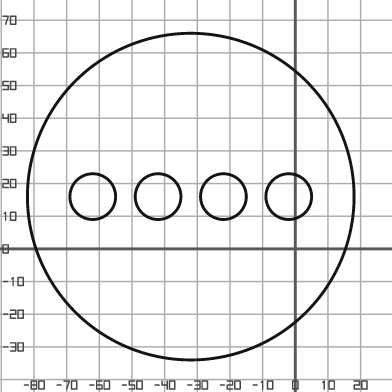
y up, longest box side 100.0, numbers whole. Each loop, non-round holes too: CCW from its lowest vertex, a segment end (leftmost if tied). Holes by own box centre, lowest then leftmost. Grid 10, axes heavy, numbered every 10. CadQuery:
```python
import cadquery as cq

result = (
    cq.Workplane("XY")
    .moveTo(-32.0, 16.0)
    .circle(50.0)
    .moveTo(-62.0, 16.0)
    .circle(7.0)
    .moveTo(-42.0, 16.0)
    .circle(7.0)
    .moveTo(-22.0, 16.0)
    .circle(7.0)
    .moveTo(-2.0, 16.0)
    .circle(7.0)
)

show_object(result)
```